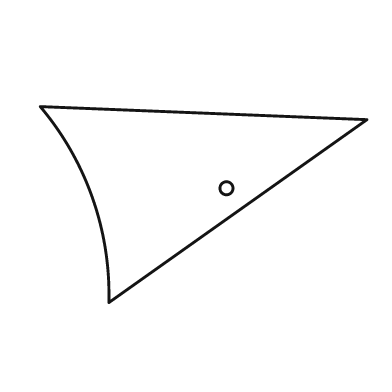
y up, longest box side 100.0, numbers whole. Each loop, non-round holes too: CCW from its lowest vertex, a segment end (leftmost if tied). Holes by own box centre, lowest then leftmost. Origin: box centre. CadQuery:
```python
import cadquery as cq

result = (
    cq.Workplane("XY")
    .moveTo(-29.0, -30.0)
    .lineTo(50.0, 26.0)
    .lineTo(-50.0, 30.0)
    .threePointArc((-34.0, 2.0), (-29.0, -30.0))
    .close()
    .moveTo(7.0, 5.0)
    .circle(2.0)
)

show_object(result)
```